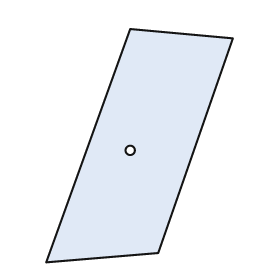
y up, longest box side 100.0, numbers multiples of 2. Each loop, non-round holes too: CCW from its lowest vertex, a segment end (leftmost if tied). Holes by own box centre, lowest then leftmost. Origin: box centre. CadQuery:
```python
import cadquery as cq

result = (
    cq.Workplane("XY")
    .moveTo(-40.0, -50.0)
    .lineTo(8.0, -46.0)
    .lineTo(40.0, 46.0)
    .lineTo(-4.0, 50.0)
    .close()
    .moveTo(-4.0, -2.0)
    .circle(2.0)
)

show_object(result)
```